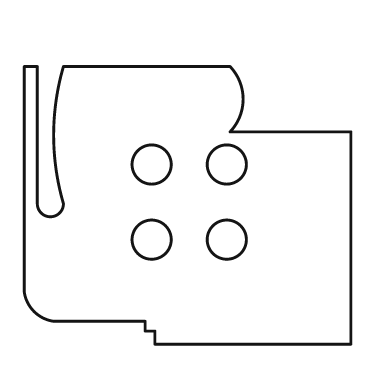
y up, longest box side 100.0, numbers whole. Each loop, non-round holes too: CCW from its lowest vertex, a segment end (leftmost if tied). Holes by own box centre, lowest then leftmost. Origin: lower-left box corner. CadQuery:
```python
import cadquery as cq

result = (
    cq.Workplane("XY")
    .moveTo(40.0, 0.0)
    .lineTo(100.0, 0.0)
    .lineTo(100.0, 65.0)
    .lineTo(63.0, 65.0)
    .threePointArc((67.0, 75.0), (63.0, 85.0))
    .lineTo(12.0, 85.0)
    .threePointArc((9.0, 64.0), (12.0, 43.0))
    .threePointArc((8.0, 39.0), (4.0, 43.0))
    .lineTo(4.0, 85.0)
    .lineTo(0.0, 85.0)
    .lineTo(0.0, 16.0)
    .threePointArc((3.0, 10.0), (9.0, 7.0))
    .lineTo(37.0, 7.0)
    .lineTo(37.0, 4.0)
    .lineTo(40.0, 4.0)
    .close()
    .moveTo(39.0, 32.0)
    .circle(6.0)
    .moveTo(62.0, 32.0)
    .circle(6.0)
    .moveTo(39.0, 55.0)
    .circle(6.0)
    .moveTo(62.0, 55.0)
    .circle(6.0)
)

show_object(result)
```